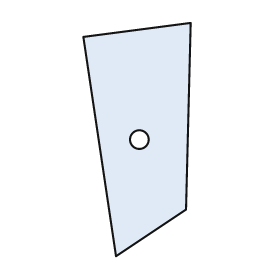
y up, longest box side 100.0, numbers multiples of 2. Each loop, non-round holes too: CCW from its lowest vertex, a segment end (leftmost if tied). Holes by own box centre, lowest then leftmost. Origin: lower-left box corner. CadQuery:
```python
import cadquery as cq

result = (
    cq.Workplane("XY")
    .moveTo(14.0, 0.0)
    .lineTo(44.0, 20.0)
    .lineTo(46.0, 100.0)
    .lineTo(0.0, 94.0)
    .close()
    .moveTo(24.0, 50.0)
    .circle(4.0)
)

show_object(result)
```